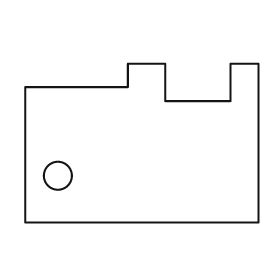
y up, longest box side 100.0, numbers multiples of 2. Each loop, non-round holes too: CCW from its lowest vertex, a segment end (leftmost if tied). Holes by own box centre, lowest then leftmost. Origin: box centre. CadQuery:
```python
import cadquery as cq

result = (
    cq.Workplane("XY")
    .moveTo(-50.0, -34.0)
    .lineTo(50.0, -34.0)
    .lineTo(50.0, 34.0)
    .lineTo(38.0, 34.0)
    .lineTo(38.0, 18.0)
    .lineTo(10.0, 18.0)
    .lineTo(10.0, 34.0)
    .lineTo(-6.0, 34.0)
    .lineTo(-6.0, 24.0)
    .lineTo(-50.0, 24.0)
    .close()
    .moveTo(-36.0, -14.0)
    .circle(6.0)
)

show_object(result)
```